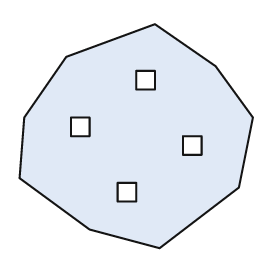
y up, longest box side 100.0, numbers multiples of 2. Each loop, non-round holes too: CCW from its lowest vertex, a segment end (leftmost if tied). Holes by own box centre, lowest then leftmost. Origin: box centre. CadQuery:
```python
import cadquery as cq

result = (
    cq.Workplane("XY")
    .moveTo(10.0, -48.0)
    .lineTo(44.0, -22.0)
    .lineTo(50.0, 8.0)
    .lineTo(34.0, 30.0)
    .lineTo(8.0, 48.0)
    .lineTo(-30.0, 34.0)
    .lineTo(-48.0, 8.0)
    .lineTo(-50.0, -18.0)
    .lineTo(-20.0, -40.0)
    .close()
    .moveTo(-8.0, -28.0)
    .lineTo(0.0, -28.0)
    .lineTo(0.0, -20.0)
    .lineTo(-8.0, -20.0)
    .close()
    .moveTo(20.0, -8.0)
    .lineTo(28.0, -8.0)
    .lineTo(28.0, 0.0)
    .lineTo(20.0, 0.0)
    .close()
    .moveTo(-28.0, 0.0)
    .lineTo(-20.0, 0.0)
    .lineTo(-20.0, 8.0)
    .lineTo(-28.0, 8.0)
    .close()
    .moveTo(0.0, 20.0)
    .lineTo(8.0, 20.0)
    .lineTo(8.0, 28.0)
    .lineTo(0.0, 28.0)
    .close()
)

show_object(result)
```